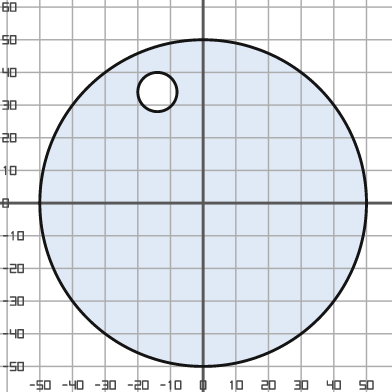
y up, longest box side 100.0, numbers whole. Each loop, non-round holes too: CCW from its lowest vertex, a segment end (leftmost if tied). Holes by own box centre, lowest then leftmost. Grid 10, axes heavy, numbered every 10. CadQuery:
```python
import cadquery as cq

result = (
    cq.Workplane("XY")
    .moveTo(0.0, 0.0)
    .circle(50.0)
    .moveTo(-14.0, 34.0)
    .circle(6.0)
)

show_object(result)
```